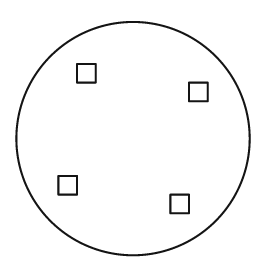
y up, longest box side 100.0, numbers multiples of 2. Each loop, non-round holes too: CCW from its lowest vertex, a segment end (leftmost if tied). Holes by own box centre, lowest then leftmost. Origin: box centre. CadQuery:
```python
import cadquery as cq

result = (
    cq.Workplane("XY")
    .moveTo(0.0, 0.0)
    .circle(50.0)
    .moveTo(16.0, -32.0)
    .lineTo(24.0, -32.0)
    .lineTo(24.0, -24.0)
    .lineTo(16.0, -24.0)
    .close()
    .moveTo(-32.0, -24.0)
    .lineTo(-24.0, -24.0)
    .lineTo(-24.0, -16.0)
    .lineTo(-32.0, -16.0)
    .close()
    .moveTo(24.0, 16.0)
    .lineTo(32.0, 16.0)
    .lineTo(32.0, 24.0)
    .lineTo(24.0, 24.0)
    .close()
    .moveTo(-24.0, 24.0)
    .lineTo(-16.0, 24.0)
    .lineTo(-16.0, 32.0)
    .lineTo(-24.0, 32.0)
    .close()
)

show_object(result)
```